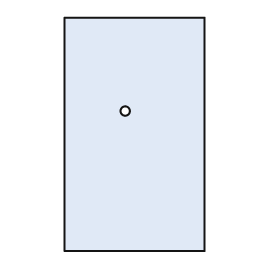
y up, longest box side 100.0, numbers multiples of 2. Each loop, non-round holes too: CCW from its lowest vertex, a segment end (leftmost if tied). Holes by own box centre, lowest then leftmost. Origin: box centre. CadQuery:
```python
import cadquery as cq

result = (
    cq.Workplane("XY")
    .moveTo(-30.0, -50.0)
    .lineTo(30.0, -50.0)
    .lineTo(30.0, 50.0)
    .lineTo(-30.0, 50.0)
    .close()
    .moveTo(-4.0, 10.0)
    .circle(2.0)
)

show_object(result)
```